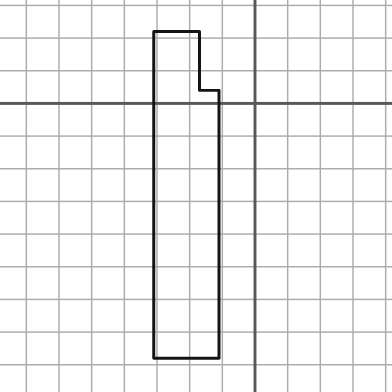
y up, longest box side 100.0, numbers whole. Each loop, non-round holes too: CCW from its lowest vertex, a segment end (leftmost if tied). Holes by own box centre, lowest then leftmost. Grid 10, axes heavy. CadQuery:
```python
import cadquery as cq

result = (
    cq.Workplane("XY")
    .moveTo(-31.0, -78.0)
    .lineTo(-11.0, -78.0)
    .lineTo(-11.0, 4.0)
    .lineTo(-17.0, 4.0)
    .lineTo(-17.0, 22.0)
    .lineTo(-31.0, 22.0)
    .close()
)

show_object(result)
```